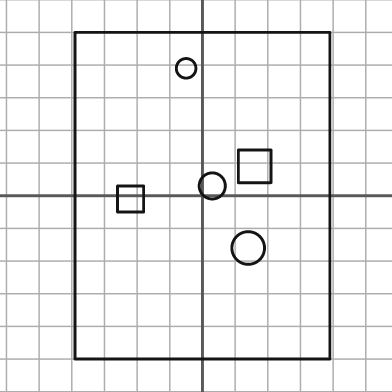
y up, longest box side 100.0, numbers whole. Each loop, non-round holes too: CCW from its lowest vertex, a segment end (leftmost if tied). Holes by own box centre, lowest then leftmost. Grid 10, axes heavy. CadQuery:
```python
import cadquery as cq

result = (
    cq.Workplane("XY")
    .moveTo(-39.0, -50.0)
    .lineTo(39.0, -50.0)
    .lineTo(39.0, 50.0)
    .lineTo(-39.0, 50.0)
    .close()
    .moveTo(14.0, -16.0)
    .circle(5.0)
    .moveTo(-26.0, -5.0)
    .lineTo(-18.0, -5.0)
    .lineTo(-18.0, 3.0)
    .lineTo(-26.0, 3.0)
    .close()
    .moveTo(3.0, 3.0)
    .circle(4.0)
    .moveTo(11.0, 4.0)
    .lineTo(21.0, 4.0)
    .lineTo(21.0, 14.0)
    .lineTo(11.0, 14.0)
    .close()
    .moveTo(-5.0, 39.0)
    .circle(3.0)
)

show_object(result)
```